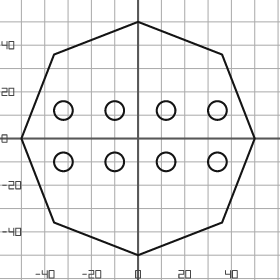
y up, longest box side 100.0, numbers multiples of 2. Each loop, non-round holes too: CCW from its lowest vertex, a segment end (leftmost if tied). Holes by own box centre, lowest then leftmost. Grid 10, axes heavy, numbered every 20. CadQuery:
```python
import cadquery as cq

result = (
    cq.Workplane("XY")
    .moveTo(0.0, -50.0)
    .lineTo(36.0, -36.0)
    .lineTo(50.0, 0.0)
    .lineTo(36.0, 36.0)
    .lineTo(0.0, 50.0)
    .lineTo(-36.0, 36.0)
    .lineTo(-50.0, 0.0)
    .lineTo(-36.0, -36.0)
    .close()
    .moveTo(-32.0, -10.0)
    .circle(4.0)
    .moveTo(-10.0, -10.0)
    .circle(4.0)
    .moveTo(12.0, -10.0)
    .circle(4.0)
    .moveTo(34.0, -10.0)
    .circle(4.0)
    .moveTo(-32.0, 12.0)
    .circle(4.0)
    .moveTo(-10.0, 12.0)
    .circle(4.0)
    .moveTo(12.0, 12.0)
    .circle(4.0)
    .moveTo(34.0, 12.0)
    .circle(4.0)
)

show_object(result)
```